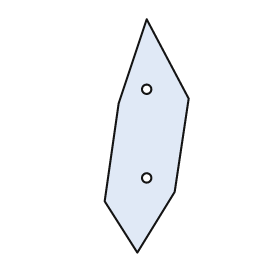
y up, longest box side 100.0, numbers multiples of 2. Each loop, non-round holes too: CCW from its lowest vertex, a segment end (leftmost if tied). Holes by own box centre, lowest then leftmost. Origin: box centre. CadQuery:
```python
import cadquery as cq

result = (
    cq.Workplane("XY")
    .moveTo(-4.0, -50.0)
    .lineTo(12.0, -24.0)
    .lineTo(18.0, 16.0)
    .lineTo(0.0, 50.0)
    .lineTo(-12.0, 14.0)
    .lineTo(-18.0, -28.0)
    .close()
    .moveTo(0.0, -18.0)
    .circle(2.0)
    .moveTo(0.0, 20.0)
    .circle(2.0)
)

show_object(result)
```